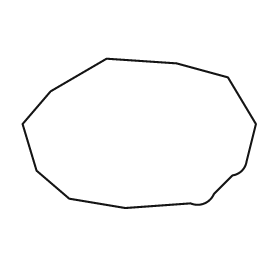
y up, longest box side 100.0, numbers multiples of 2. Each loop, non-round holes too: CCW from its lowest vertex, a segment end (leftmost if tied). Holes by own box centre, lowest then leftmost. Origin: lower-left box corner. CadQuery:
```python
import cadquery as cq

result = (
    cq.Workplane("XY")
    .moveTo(44.0, 0.0)
    .lineTo(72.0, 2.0)
    .threePointArc((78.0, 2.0), (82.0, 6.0))
    .lineTo(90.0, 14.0)
    .threePointArc((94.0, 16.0), (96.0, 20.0))
    .lineTo(100.0, 36.0)
    .lineTo(88.0, 56.0)
    .lineTo(66.0, 62.0)
    .lineTo(36.0, 64.0)
    .lineTo(12.0, 50.0)
    .lineTo(0.0, 36.0)
    .lineTo(6.0, 16.0)
    .lineTo(20.0, 4.0)
    .close()
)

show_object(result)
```